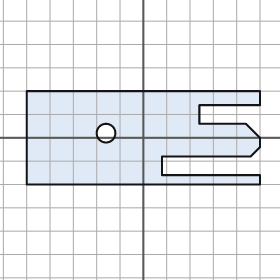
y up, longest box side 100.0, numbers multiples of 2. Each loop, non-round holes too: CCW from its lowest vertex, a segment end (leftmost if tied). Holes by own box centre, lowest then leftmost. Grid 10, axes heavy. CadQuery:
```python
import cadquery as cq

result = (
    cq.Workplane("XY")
    .moveTo(-50.0, -20.0)
    .lineTo(50.0, -20.0)
    .lineTo(50.0, -16.0)
    .lineTo(8.0, -16.0)
    .lineTo(8.0, -8.0)
    .lineTo(46.0, -8.0)
    .lineTo(50.0, -4.0)
    .lineTo(50.0, 0.0)
    .lineTo(44.0, 6.0)
    .lineTo(24.0, 6.0)
    .lineTo(24.0, 14.0)
    .lineTo(50.0, 14.0)
    .lineTo(50.0, 20.0)
    .lineTo(-50.0, 20.0)
    .close()
    .moveTo(-16.0, 2.0)
    .circle(4.0)
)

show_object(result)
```